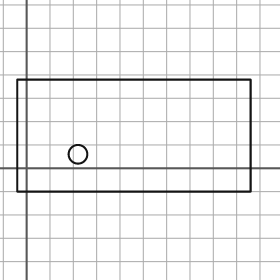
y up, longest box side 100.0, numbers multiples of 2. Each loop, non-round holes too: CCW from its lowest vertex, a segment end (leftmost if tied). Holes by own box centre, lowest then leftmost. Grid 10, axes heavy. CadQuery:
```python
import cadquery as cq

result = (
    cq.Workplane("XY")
    .moveTo(-4.0, -10.0)
    .lineTo(96.0, -10.0)
    .lineTo(96.0, 38.0)
    .lineTo(-4.0, 38.0)
    .close()
    .moveTo(22.0, 6.0)
    .circle(4.0)
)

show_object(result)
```